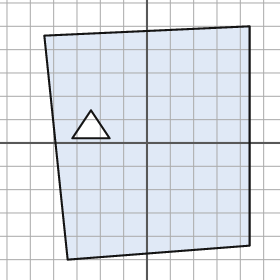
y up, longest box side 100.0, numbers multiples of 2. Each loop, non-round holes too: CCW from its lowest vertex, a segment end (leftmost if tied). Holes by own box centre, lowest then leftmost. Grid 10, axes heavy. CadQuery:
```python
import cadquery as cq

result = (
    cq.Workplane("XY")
    .moveTo(-34.0, -50.0)
    .lineTo(44.0, -44.0)
    .lineTo(44.0, 50.0)
    .lineTo(-44.0, 46.0)
    .close()
    .moveTo(-32.0, 2.0)
    .lineTo(-16.0, 2.0)
    .lineTo(-24.0, 14.0)
    .close()
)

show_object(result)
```